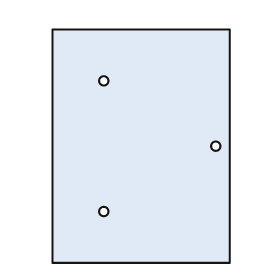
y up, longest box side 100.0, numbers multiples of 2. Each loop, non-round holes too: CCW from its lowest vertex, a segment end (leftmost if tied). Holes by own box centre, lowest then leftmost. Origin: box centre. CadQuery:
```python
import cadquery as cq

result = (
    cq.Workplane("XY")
    .moveTo(-38.0, -50.0)
    .lineTo(38.0, -50.0)
    .lineTo(38.0, 50.0)
    .lineTo(-38.0, 50.0)
    .close()
    .moveTo(-16.0, -28.0)
    .circle(2.0)
    .moveTo(32.0, 0.0)
    .circle(2.0)
    .moveTo(-16.0, 28.0)
    .circle(2.0)
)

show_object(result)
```